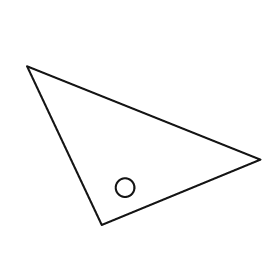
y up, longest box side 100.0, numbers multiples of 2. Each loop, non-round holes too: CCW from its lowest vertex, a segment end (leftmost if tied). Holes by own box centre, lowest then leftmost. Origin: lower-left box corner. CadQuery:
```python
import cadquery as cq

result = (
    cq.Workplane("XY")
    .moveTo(32.0, 0.0)
    .lineTo(100.0, 28.0)
    .lineTo(0.0, 68.0)
    .close()
    .moveTo(42.0, 16.0)
    .circle(4.0)
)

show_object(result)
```